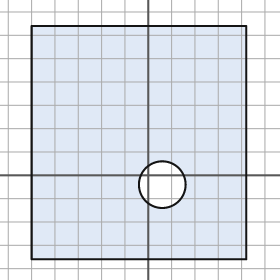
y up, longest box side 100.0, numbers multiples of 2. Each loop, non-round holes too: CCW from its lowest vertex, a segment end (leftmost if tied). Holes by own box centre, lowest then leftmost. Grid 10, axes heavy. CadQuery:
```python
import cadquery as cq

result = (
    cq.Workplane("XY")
    .moveTo(-50.0, -36.0)
    .lineTo(42.0, -36.0)
    .lineTo(42.0, 64.0)
    .lineTo(-50.0, 64.0)
    .close()
    .moveTo(6.0, -4.0)
    .circle(10.0)
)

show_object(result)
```